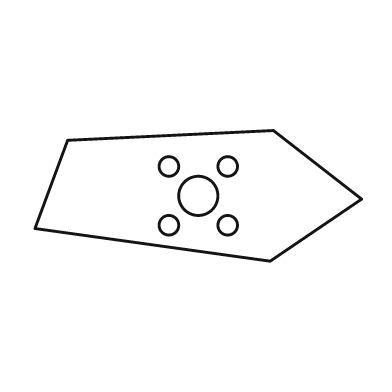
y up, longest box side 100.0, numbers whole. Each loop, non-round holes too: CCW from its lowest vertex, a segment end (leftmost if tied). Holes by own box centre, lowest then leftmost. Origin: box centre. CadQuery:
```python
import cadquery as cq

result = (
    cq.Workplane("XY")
    .moveTo(22.0, -20.0)
    .lineTo(50.0, -1.0)
    .lineTo(23.0, 20.0)
    .lineTo(-40.0, 17.0)
    .lineTo(-50.0, -10.0)
    .close()
    .moveTo(-9.0, -9.0)
    .circle(3.0)
    .moveTo(9.0, -9.0)
    .circle(3.0)
    .moveTo(0.0, 0.0)
    .circle(6.0)
    .moveTo(-9.0, 9.0)
    .circle(3.0)
    .moveTo(9.0, 9.0)
    .circle(3.0)
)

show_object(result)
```